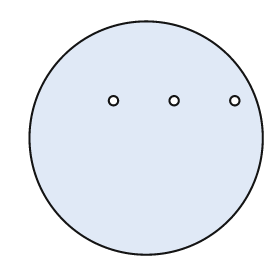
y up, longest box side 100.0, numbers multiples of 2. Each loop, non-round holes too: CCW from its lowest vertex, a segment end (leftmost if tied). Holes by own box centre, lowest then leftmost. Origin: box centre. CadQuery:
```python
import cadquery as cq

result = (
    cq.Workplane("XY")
    .moveTo(0.0, 0.0)
    .circle(50.0)
    .moveTo(-14.0, 16.0)
    .circle(2.0)
    .moveTo(12.0, 16.0)
    .circle(2.0)
    .moveTo(38.0, 16.0)
    .circle(2.0)
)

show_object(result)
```